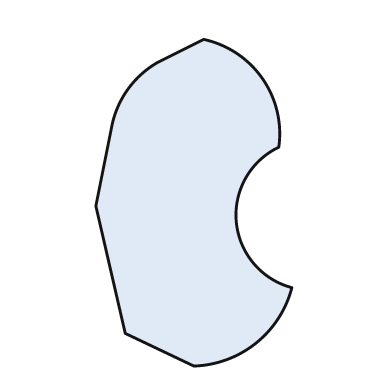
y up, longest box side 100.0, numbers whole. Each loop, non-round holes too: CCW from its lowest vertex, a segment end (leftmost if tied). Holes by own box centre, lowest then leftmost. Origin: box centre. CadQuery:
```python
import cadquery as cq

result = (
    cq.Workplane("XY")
    .moveTo(0.0, -50.0)
    .threePointArc((19.0, -43.0), (30.0, -26.0))
    .threePointArc((13.0, -6.0), (26.0, 17.0))
    .threePointArc((21.0, 38.0), (3.0, 50.0))
    .lineTo(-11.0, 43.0)
    .threePointArc((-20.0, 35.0), (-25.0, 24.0))
    .lineTo(-30.0, -1.0)
    .lineTo(-21.0, -40.0)
    .close()
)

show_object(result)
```